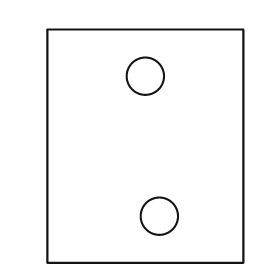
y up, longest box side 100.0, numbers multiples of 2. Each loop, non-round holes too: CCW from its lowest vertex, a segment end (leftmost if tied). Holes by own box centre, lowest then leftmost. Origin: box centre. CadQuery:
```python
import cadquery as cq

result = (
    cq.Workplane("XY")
    .moveTo(-42.0, -50.0)
    .lineTo(42.0, -50.0)
    .lineTo(42.0, 50.0)
    .lineTo(-42.0, 50.0)
    .close()
    .moveTo(6.0, -30.0)
    .circle(8.0)
    .moveTo(0.0, 30.0)
    .circle(8.0)
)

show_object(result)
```